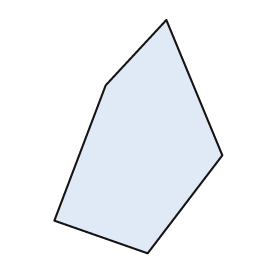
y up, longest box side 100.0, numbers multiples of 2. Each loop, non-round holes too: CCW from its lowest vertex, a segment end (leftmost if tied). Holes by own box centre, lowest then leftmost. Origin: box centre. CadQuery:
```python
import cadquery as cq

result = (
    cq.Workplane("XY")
    .moveTo(4.0, -50.0)
    .lineTo(36.0, -8.0)
    .lineTo(12.0, 50.0)
    .lineTo(-14.0, 22.0)
    .lineTo(-36.0, -36.0)
    .close()
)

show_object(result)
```